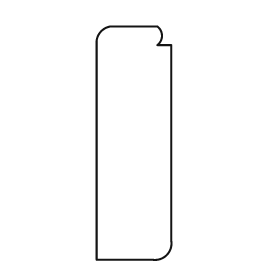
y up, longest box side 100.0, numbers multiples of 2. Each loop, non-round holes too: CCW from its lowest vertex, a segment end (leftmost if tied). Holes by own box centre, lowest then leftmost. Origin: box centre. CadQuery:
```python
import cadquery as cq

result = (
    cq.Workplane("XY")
    .moveTo(-16.0, -50.0)
    .lineTo(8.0, -50.0)
    .threePointArc((14.0, -48.0), (16.0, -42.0))
    .lineTo(16.0, 42.0)
    .lineTo(10.0, 42.0)
    .threePointArc((12.0, 46.0), (10.0, 50.0))
    .lineTo(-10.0, 50.0)
    .threePointArc((-14.0, 48.0), (-16.0, 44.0))
    .close()
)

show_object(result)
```